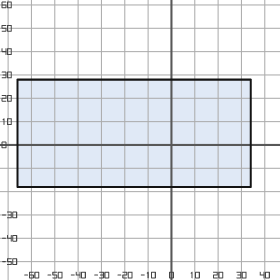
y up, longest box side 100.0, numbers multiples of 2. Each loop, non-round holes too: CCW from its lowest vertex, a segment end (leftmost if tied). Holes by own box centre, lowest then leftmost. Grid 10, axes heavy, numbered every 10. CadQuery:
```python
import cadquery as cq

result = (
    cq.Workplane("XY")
    .moveTo(-66.0, -18.0)
    .lineTo(34.0, -18.0)
    .lineTo(34.0, 28.0)
    .lineTo(-66.0, 28.0)
    .close()
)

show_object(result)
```